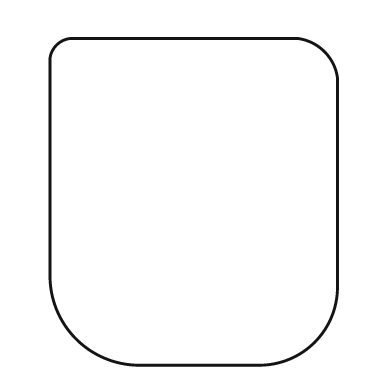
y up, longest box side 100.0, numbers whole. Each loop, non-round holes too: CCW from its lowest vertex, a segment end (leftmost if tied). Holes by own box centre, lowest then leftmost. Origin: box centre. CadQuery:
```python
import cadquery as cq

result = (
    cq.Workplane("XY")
    .moveTo(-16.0, -50.0)
    .lineTo(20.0, -50.0)
    .threePointArc((37.0, -43.0), (44.0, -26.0))
    .lineTo(44.0, 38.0)
    .threePointArc((40.0, 46.0), (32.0, 50.0))
    .lineTo(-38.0, 50.0)
    .threePointArc((-42.0, 48.0), (-44.0, 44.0))
    .lineTo(-44.0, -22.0)
    .threePointArc((-36.0, -42.0), (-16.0, -50.0))
    .close()
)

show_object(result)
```